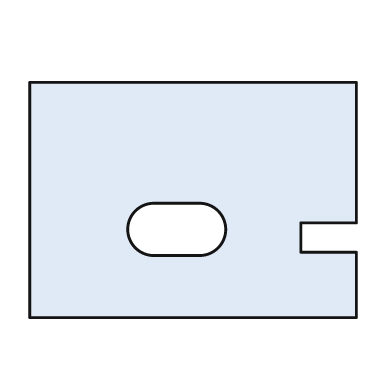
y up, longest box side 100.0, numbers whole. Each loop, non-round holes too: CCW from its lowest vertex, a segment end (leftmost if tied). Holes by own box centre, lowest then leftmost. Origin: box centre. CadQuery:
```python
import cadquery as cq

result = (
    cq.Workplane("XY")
    .moveTo(-50.0, -36.0)
    .lineTo(50.0, -36.0)
    .lineTo(50.0, -16.0)
    .lineTo(33.0, -16.0)
    .lineTo(33.0, -7.0)
    .lineTo(50.0, -7.0)
    .lineTo(50.0, 36.0)
    .lineTo(-50.0, 36.0)
    .close()
    .moveTo(-12.0, -17.0)
    .lineTo(2.0, -17.0)
    .threePointArc((10.0, -9.0), (2.0, -1.0))
    .lineTo(-12.0, -1.0)
    .threePointArc((-20.0, -9.0), (-12.0, -17.0))
    .close()
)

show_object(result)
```